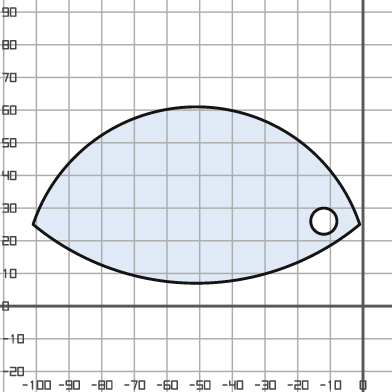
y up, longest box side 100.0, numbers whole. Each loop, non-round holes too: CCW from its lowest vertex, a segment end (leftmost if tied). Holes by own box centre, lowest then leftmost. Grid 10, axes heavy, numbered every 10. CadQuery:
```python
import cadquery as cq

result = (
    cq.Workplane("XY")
    .moveTo(-101.0, 25.0)
    .threePointArc((-51.0, 7.0), (-1.0, 25.0))
    .threePointArc((-51.0, 61.0), (-101.0, 25.0))
    .close()
    .moveTo(-12.0, 26.0)
    .circle(4.0)
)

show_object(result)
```